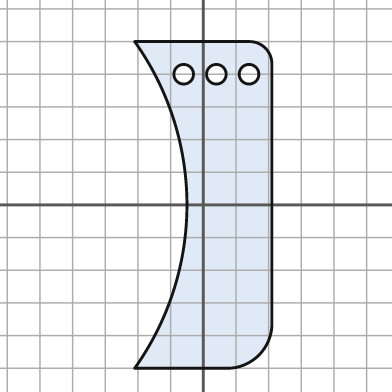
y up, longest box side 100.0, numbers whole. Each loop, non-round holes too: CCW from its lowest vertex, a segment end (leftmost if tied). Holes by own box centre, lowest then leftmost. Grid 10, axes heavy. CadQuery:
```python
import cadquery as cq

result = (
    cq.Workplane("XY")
    .moveTo(-21.0, -50.0)
    .lineTo(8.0, -50.0)
    .threePointArc((17.0, -46.0), (21.0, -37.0))
    .lineTo(21.0, 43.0)
    .threePointArc((19.0, 48.0), (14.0, 50.0))
    .lineTo(-21.0, 50.0)
    .threePointArc((-5.0, 0.0), (-21.0, -50.0))
    .close()
    .moveTo(-6.0, 40.0)
    .circle(3.0)
    .moveTo(4.0, 40.0)
    .circle(3.0)
    .moveTo(14.0, 40.0)
    .circle(3.0)
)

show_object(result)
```